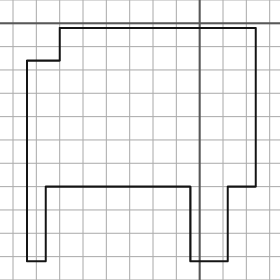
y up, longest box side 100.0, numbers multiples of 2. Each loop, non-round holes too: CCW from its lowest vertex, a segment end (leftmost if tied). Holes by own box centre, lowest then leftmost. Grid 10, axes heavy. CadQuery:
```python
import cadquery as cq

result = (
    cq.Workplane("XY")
    .moveTo(-74.0, -102.0)
    .lineTo(-66.0, -102.0)
    .lineTo(-66.0, -70.0)
    .lineTo(-4.0, -70.0)
    .lineTo(-4.0, -102.0)
    .lineTo(12.0, -102.0)
    .lineTo(12.0, -70.0)
    .lineTo(24.0, -70.0)
    .lineTo(24.0, -2.0)
    .lineTo(-60.0, -2.0)
    .lineTo(-60.0, -16.0)
    .lineTo(-74.0, -16.0)
    .close()
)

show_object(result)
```